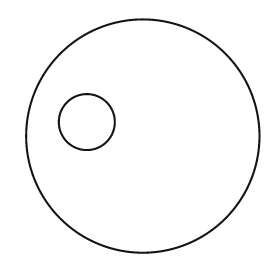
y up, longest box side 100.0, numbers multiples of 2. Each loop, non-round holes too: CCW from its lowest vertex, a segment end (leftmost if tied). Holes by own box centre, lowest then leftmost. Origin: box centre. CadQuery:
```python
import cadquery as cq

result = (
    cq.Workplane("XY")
    .moveTo(0.0, 0.0)
    .circle(50.0)
    .moveTo(-24.0, 6.0)
    .circle(12.0)
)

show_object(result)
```